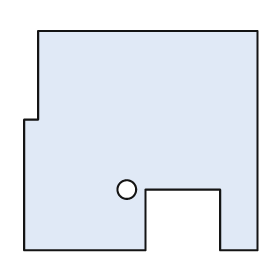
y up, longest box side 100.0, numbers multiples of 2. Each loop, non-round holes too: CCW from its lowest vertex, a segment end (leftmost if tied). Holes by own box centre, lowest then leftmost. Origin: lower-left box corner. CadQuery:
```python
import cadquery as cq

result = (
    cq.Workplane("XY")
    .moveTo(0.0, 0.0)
    .lineTo(52.0, 0.0)
    .lineTo(52.0, 26.0)
    .lineTo(84.0, 26.0)
    .lineTo(84.0, 0.0)
    .lineTo(100.0, 0.0)
    .lineTo(100.0, 94.0)
    .lineTo(6.0, 94.0)
    .lineTo(6.0, 56.0)
    .lineTo(0.0, 56.0)
    .close()
    .moveTo(44.0, 26.0)
    .circle(4.0)
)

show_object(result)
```